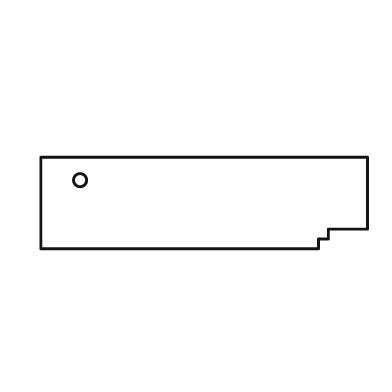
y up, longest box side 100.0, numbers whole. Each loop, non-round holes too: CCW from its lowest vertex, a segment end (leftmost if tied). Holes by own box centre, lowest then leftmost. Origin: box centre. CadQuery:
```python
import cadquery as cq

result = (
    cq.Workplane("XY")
    .moveTo(-50.0, -14.0)
    .lineTo(35.0, -14.0)
    .lineTo(35.0, -11.0)
    .lineTo(38.0, -11.0)
    .lineTo(38.0, -8.0)
    .lineTo(50.0, -8.0)
    .lineTo(50.0, 14.0)
    .lineTo(-50.0, 14.0)
    .close()
    .moveTo(-38.0, 7.0)
    .circle(2.0)
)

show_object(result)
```